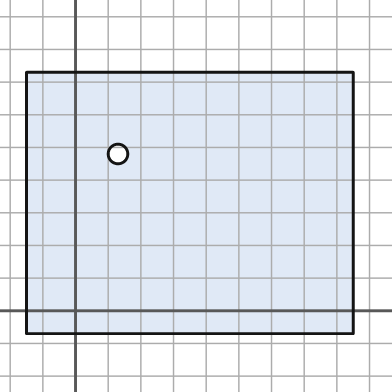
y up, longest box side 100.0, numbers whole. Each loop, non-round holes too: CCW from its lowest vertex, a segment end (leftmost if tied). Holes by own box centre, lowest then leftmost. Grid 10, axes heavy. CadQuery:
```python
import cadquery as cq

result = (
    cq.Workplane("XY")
    .moveTo(-15.0, -7.0)
    .lineTo(85.0, -7.0)
    .lineTo(85.0, 73.0)
    .lineTo(-15.0, 73.0)
    .close()
    .moveTo(13.0, 48.0)
    .circle(3.0)
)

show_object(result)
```